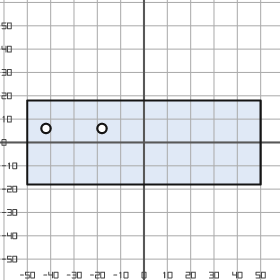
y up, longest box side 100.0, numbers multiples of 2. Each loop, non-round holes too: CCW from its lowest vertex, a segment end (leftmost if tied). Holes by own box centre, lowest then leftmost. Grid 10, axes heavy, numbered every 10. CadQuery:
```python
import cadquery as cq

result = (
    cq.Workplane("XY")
    .moveTo(-50.0, -18.0)
    .lineTo(50.0, -18.0)
    .lineTo(50.0, 18.0)
    .lineTo(-50.0, 18.0)
    .close()
    .moveTo(-42.0, 6.0)
    .circle(2.0)
    .moveTo(-18.0, 6.0)
    .circle(2.0)
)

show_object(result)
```